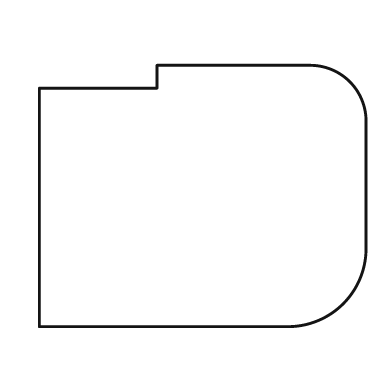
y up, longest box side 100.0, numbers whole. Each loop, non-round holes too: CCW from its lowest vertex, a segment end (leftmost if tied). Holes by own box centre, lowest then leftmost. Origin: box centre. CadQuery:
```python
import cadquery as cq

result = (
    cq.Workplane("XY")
    .moveTo(-50.0, -40.0)
    .lineTo(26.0, -40.0)
    .threePointArc((43.0, -33.0), (50.0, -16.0))
    .lineTo(50.0, 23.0)
    .threePointArc((45.0, 35.0), (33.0, 40.0))
    .lineTo(-14.0, 40.0)
    .lineTo(-14.0, 33.0)
    .lineTo(-50.0, 33.0)
    .close()
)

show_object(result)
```